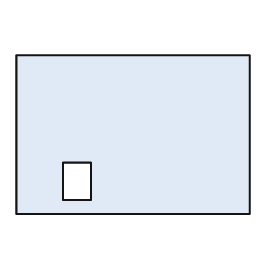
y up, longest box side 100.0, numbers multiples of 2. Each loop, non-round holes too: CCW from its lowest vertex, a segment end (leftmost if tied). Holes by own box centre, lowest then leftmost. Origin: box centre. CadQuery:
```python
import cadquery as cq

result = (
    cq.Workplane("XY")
    .moveTo(-50.0, -34.0)
    .lineTo(50.0, -34.0)
    .lineTo(50.0, 34.0)
    .lineTo(-50.0, 34.0)
    .close()
    .moveTo(-30.0, -28.0)
    .lineTo(-18.0, -28.0)
    .lineTo(-18.0, -12.0)
    .lineTo(-30.0, -12.0)
    .close()
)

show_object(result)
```